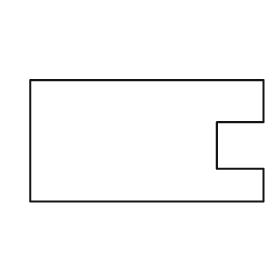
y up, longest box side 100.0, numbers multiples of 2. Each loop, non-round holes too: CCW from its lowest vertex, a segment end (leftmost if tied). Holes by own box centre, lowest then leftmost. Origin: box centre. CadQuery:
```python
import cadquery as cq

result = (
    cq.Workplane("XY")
    .moveTo(-50.0, -26.0)
    .lineTo(50.0, -26.0)
    .lineTo(50.0, -12.0)
    .lineTo(30.0, -12.0)
    .lineTo(30.0, 8.0)
    .lineTo(50.0, 8.0)
    .lineTo(50.0, 26.0)
    .lineTo(-50.0, 26.0)
    .close()
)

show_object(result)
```